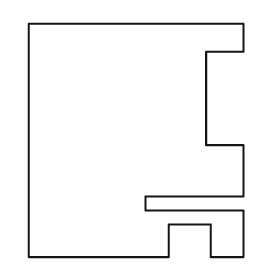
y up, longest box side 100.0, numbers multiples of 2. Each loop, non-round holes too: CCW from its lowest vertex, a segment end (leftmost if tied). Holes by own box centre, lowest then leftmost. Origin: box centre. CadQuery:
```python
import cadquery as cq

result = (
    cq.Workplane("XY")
    .moveTo(-46.0, -50.0)
    .lineTo(14.0, -50.0)
    .lineTo(14.0, -36.0)
    .lineTo(32.0, -36.0)
    .lineTo(32.0, -50.0)
    .lineTo(46.0, -50.0)
    .lineTo(46.0, -30.0)
    .lineTo(4.0, -30.0)
    .lineTo(4.0, -24.0)
    .lineTo(46.0, -24.0)
    .lineTo(46.0, -2.0)
    .lineTo(30.0, -2.0)
    .lineTo(30.0, 38.0)
    .lineTo(46.0, 38.0)
    .lineTo(46.0, 50.0)
    .lineTo(-46.0, 50.0)
    .close()
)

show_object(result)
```